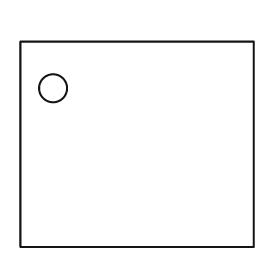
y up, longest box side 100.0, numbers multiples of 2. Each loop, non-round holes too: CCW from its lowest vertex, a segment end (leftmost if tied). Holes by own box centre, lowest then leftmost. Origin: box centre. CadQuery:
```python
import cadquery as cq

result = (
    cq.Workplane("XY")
    .moveTo(-50.0, -44.0)
    .lineTo(50.0, -44.0)
    .lineTo(50.0, 44.0)
    .lineTo(-50.0, 44.0)
    .close()
    .moveTo(-36.0, 24.0)
    .circle(6.0)
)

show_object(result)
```